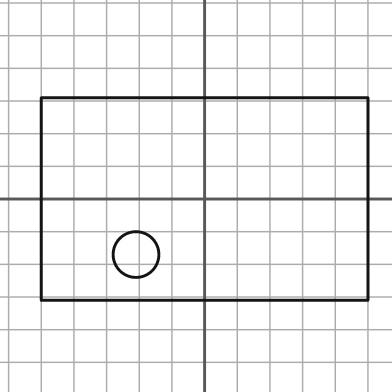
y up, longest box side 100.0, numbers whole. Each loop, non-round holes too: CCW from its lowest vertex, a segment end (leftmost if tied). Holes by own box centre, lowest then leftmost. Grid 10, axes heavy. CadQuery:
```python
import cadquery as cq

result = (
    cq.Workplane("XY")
    .moveTo(-50.0, -31.0)
    .lineTo(50.0, -31.0)
    .lineTo(50.0, 31.0)
    .lineTo(-50.0, 31.0)
    .close()
    .moveTo(-21.0, -17.0)
    .circle(7.0)
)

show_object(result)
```